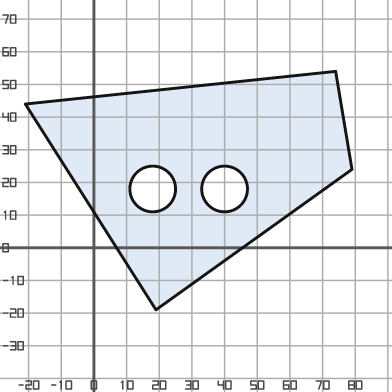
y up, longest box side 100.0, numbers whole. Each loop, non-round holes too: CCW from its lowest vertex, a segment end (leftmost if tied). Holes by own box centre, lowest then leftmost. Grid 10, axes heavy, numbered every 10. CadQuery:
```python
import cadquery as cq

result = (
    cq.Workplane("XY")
    .moveTo(19.0, -19.0)
    .lineTo(79.0, 24.0)
    .lineTo(74.0, 54.0)
    .lineTo(-21.0, 44.0)
    .close()
    .moveTo(18.0, 18.0)
    .circle(7.0)
    .moveTo(40.0, 18.0)
    .circle(7.0)
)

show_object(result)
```